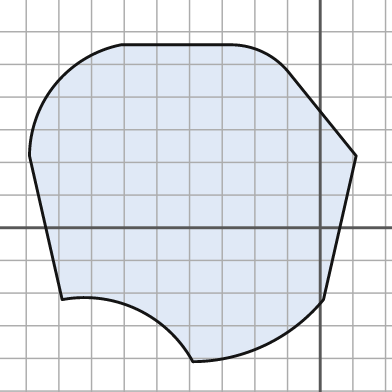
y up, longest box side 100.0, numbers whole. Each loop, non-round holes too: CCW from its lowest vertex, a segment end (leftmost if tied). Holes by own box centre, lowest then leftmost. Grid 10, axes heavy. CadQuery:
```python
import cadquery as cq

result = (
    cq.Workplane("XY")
    .moveTo(-39.0, -41.0)
    .threePointArc((-17.0, -36.0), (1.0, -22.0))
    .lineTo(11.0, 22.0)
    .lineTo(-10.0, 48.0)
    .threePointArc((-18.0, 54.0), (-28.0, 56.0))
    .lineTo(-61.0, 56.0)
    .threePointArc((-81.0, 44.0), (-89.0, 22.0))
    .lineTo(-79.0, -22.0)
    .threePointArc((-56.0, -25.0), (-39.0, -41.0))
    .close()
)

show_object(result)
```